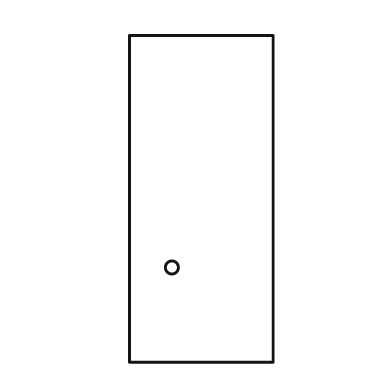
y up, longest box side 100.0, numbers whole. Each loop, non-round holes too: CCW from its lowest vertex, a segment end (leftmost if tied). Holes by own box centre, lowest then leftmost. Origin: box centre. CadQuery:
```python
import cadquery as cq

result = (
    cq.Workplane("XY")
    .moveTo(-22.0, -50.0)
    .lineTo(22.0, -50.0)
    .lineTo(22.0, 50.0)
    .lineTo(-22.0, 50.0)
    .close()
    .moveTo(-9.0, -21.0)
    .circle(2.0)
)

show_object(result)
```